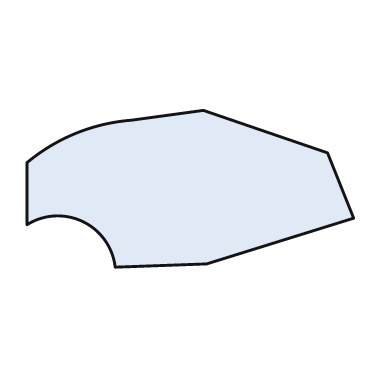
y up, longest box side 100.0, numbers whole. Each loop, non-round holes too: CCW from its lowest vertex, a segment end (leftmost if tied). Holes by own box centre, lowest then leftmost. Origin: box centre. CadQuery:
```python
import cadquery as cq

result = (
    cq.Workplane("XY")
    .moveTo(-23.0, -24.0)
    .lineTo(5.0, -23.0)
    .lineTo(50.0, -9.0)
    .lineTo(42.0, 11.0)
    .lineTo(4.0, 24.0)
    .lineTo(-18.0, 21.0)
    .threePointArc((-35.0, 17.0), (-50.0, 8.0))
    .lineTo(-50.0, -11.0)
    .threePointArc((-33.0, -10.0), (-23.0, -24.0))
    .close()
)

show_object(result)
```